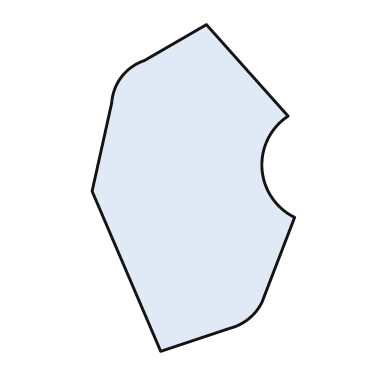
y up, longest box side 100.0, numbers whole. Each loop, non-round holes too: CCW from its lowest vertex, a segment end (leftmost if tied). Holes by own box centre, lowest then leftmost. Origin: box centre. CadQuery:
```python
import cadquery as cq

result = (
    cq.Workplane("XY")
    .moveTo(-10.0, -50.0)
    .lineTo(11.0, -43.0)
    .threePointArc((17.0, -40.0), (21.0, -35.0))
    .lineTo(31.0, -9.0)
    .threePointArc((21.0, 6.0), (29.0, 22.0))
    .lineTo(4.0, 50.0)
    .lineTo(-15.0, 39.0)
    .threePointArc((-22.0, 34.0), (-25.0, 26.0))
    .lineTo(-31.0, -1.0)
    .close()
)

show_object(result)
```